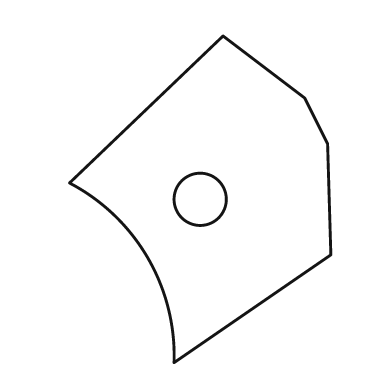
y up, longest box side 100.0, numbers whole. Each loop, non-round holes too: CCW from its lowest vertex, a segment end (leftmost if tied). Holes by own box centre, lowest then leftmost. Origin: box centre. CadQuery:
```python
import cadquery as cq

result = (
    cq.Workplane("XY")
    .moveTo(-8.0, -50.0)
    .lineTo(40.0, -17.0)
    .lineTo(39.0, 17.0)
    .lineTo(32.0, 31.0)
    .lineTo(7.0, 50.0)
    .lineTo(-40.0, 5.0)
    .threePointArc((-16.0, -18.0), (-8.0, -50.0))
    .close()
    .moveTo(0.0, 0.0)
    .circle(8.0)
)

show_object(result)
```